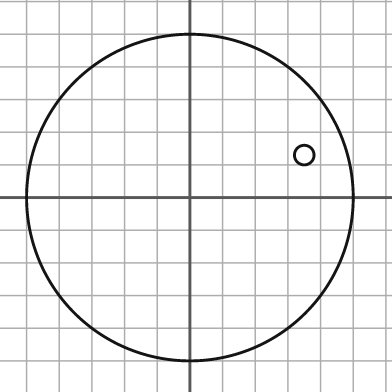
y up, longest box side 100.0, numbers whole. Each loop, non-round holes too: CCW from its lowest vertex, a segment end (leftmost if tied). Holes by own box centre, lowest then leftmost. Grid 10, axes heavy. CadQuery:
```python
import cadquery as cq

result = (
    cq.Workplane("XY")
    .moveTo(0.0, 0.0)
    .circle(50.0)
    .moveTo(35.0, 13.0)
    .circle(3.0)
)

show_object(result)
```